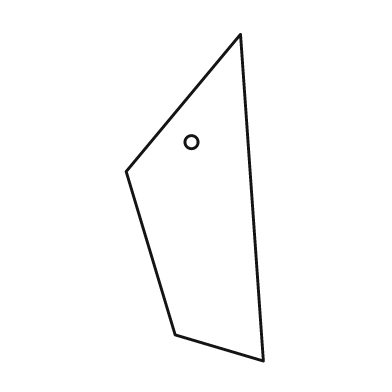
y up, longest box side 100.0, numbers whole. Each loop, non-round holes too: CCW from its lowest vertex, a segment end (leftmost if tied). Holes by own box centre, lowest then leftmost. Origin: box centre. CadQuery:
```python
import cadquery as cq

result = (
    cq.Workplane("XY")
    .moveTo(21.0, -50.0)
    .lineTo(14.0, 50.0)
    .lineTo(-21.0, 8.0)
    .lineTo(-6.0, -42.0)
    .close()
    .moveTo(-1.0, 17.0)
    .circle(2.0)
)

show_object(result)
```